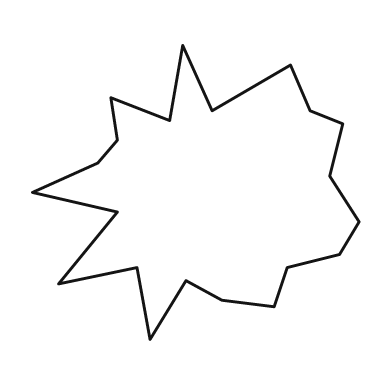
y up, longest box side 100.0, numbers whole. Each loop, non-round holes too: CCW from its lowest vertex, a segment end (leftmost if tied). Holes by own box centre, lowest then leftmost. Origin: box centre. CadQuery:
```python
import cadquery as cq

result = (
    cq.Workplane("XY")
    .moveTo(-14.0, -45.0)
    .lineTo(-3.0, -27.0)
    .lineTo(8.0, -33.0)
    .lineTo(24.0, -35.0)
    .lineTo(28.0, -23.0)
    .lineTo(44.0, -19.0)
    .lineTo(50.0, -9.0)
    .lineTo(41.0, 5.0)
    .lineTo(45.0, 21.0)
    .lineTo(35.0, 25.0)
    .lineTo(29.0, 39.0)
    .lineTo(5.0, 25.0)
    .lineTo(-4.0, 45.0)
    .lineTo(-8.0, 22.0)
    .lineTo(-26.0, 29.0)
    .lineTo(-24.0, 16.0)
    .lineTo(-30.0, 9.0)
    .lineTo(-50.0, 0.0)
    .lineTo(-24.0, -6.0)
    .lineTo(-42.0, -28.0)
    .lineTo(-18.0, -23.0)
    .close()
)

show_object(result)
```